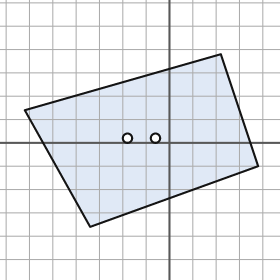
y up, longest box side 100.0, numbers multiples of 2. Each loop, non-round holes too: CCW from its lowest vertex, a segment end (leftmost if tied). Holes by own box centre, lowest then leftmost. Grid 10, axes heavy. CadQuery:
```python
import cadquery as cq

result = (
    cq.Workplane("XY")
    .moveTo(-34.0, -36.0)
    .lineTo(38.0, -10.0)
    .lineTo(22.0, 38.0)
    .lineTo(-62.0, 14.0)
    .close()
    .moveTo(-18.0, 2.0)
    .circle(2.0)
    .moveTo(-6.0, 2.0)
    .circle(2.0)
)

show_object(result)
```